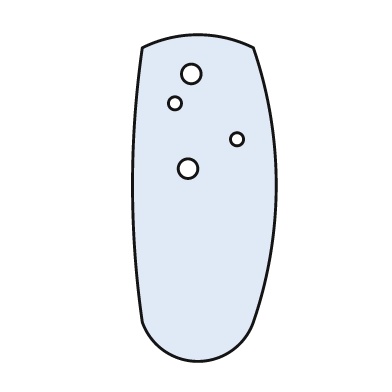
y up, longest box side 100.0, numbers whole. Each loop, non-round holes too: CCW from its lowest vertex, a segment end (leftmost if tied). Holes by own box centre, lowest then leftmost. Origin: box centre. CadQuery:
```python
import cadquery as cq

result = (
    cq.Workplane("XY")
    .moveTo(-19.0, -38.0)
    .threePointArc((-2.0, -50.0), (15.0, -38.0))
    .threePointArc((22.0, 4.0), (15.0, 46.0))
    .threePointArc((-2.0, 50.0), (-19.0, 46.0))
    .threePointArc((-22.0, 4.0), (-19.0, -38.0))
    .close()
    .moveTo(-5.0, 9.0)
    .circle(3.0)
    .moveTo(10.0, 18.0)
    .circle(2.0)
    .moveTo(-9.0, 29.0)
    .circle(2.0)
    .moveTo(-4.0, 38.0)
    .circle(3.0)
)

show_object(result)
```